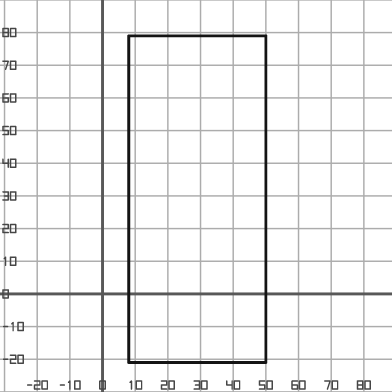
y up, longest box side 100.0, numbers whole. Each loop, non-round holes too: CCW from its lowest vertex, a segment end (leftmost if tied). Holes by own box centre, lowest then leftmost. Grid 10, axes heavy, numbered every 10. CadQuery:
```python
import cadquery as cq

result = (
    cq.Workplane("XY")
    .moveTo(8.0, -21.0)
    .lineTo(50.0, -21.0)
    .lineTo(50.0, 79.0)
    .lineTo(8.0, 79.0)
    .close()
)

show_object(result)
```